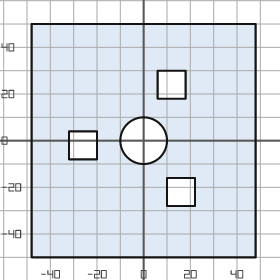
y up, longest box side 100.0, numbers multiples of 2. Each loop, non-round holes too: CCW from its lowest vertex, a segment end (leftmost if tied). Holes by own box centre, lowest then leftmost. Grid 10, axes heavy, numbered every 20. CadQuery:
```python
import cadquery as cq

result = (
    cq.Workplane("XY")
    .moveTo(-48.0, -50.0)
    .lineTo(48.0, -50.0)
    .lineTo(48.0, 50.0)
    .lineTo(-48.0, 50.0)
    .close()
    .moveTo(10.0, -28.0)
    .lineTo(22.0, -28.0)
    .lineTo(22.0, -16.0)
    .lineTo(10.0, -16.0)
    .close()
    .moveTo(-32.0, -8.0)
    .lineTo(-20.0, -8.0)
    .lineTo(-20.0, 4.0)
    .lineTo(-32.0, 4.0)
    .close()
    .moveTo(0.0, 0.0)
    .circle(10.0)
    .moveTo(6.0, 18.0)
    .lineTo(18.0, 18.0)
    .lineTo(18.0, 30.0)
    .lineTo(6.0, 30.0)
    .close()
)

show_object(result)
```